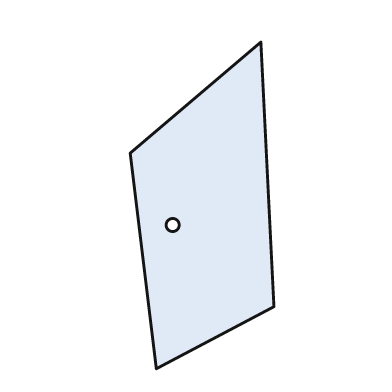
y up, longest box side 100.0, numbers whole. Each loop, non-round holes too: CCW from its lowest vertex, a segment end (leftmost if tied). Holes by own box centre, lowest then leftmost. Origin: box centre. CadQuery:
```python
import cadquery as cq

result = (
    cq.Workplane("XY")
    .moveTo(-14.0, -50.0)
    .lineTo(22.0, -31.0)
    .lineTo(18.0, 50.0)
    .lineTo(-22.0, 16.0)
    .close()
    .moveTo(-9.0, -6.0)
    .circle(2.0)
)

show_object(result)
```